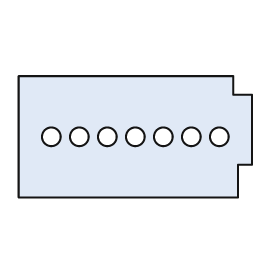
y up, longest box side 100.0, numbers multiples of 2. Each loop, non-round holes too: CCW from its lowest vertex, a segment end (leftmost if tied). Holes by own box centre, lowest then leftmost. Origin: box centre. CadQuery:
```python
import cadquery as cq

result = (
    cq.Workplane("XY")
    .moveTo(-50.0, -26.0)
    .lineTo(44.0, -26.0)
    .lineTo(44.0, -12.0)
    .lineTo(50.0, -12.0)
    .lineTo(50.0, 18.0)
    .lineTo(42.0, 18.0)
    .lineTo(42.0, 26.0)
    .lineTo(-50.0, 26.0)
    .close()
    .moveTo(-36.0, 0.0)
    .circle(4.0)
    .moveTo(-24.0, 0.0)
    .circle(4.0)
    .moveTo(-12.0, 0.0)
    .circle(4.0)
    .moveTo(0.0, 0.0)
    .circle(4.0)
    .moveTo(12.0, 0.0)
    .circle(4.0)
    .moveTo(24.0, 0.0)
    .circle(4.0)
    .moveTo(36.0, 0.0)
    .circle(4.0)
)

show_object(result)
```